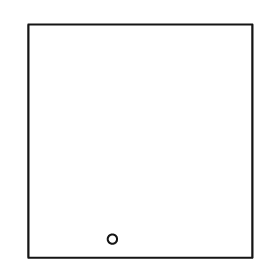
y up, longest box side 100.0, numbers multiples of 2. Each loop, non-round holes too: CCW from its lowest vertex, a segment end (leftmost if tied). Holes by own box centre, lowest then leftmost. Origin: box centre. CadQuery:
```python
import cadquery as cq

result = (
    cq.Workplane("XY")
    .moveTo(-48.0, -50.0)
    .lineTo(48.0, -50.0)
    .lineTo(48.0, 50.0)
    .lineTo(-48.0, 50.0)
    .close()
    .moveTo(-12.0, -42.0)
    .circle(2.0)
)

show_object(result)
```